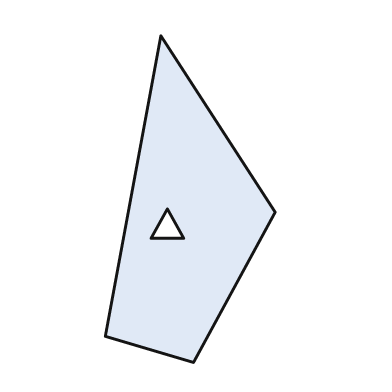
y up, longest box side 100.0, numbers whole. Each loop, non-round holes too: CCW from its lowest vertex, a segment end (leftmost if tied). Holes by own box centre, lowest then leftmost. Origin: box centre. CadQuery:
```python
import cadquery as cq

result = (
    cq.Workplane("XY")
    .moveTo(1.0, -50.0)
    .lineTo(26.0, -4.0)
    .lineTo(-9.0, 50.0)
    .lineTo(-26.0, -42.0)
    .close()
    .moveTo(-12.0, -12.0)
    .lineTo(-2.0, -12.0)
    .lineTo(-7.0, -3.0)
    .close()
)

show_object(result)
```